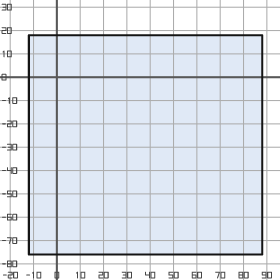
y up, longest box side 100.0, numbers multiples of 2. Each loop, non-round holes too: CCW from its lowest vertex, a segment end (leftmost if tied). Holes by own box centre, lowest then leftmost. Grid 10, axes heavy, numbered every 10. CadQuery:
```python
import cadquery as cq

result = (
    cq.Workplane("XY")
    .moveTo(-12.0, -76.0)
    .lineTo(88.0, -76.0)
    .lineTo(88.0, 18.0)
    .lineTo(-12.0, 18.0)
    .close()
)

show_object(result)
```